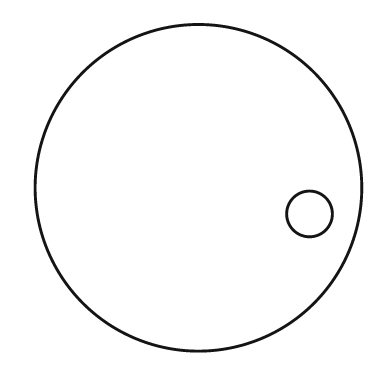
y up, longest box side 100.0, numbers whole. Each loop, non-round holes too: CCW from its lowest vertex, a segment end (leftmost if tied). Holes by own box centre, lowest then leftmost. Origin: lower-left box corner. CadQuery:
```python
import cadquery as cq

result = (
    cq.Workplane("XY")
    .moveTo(50.0, 50.0)
    .circle(50.0)
    .moveTo(84.0, 42.0)
    .circle(7.0)
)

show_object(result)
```